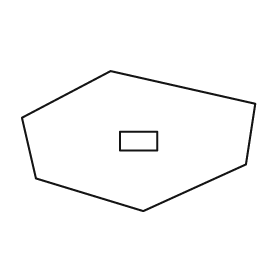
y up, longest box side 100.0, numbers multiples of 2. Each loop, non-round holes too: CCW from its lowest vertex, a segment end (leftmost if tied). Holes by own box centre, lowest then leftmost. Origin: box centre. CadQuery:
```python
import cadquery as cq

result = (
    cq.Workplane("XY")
    .moveTo(2.0, -30.0)
    .lineTo(46.0, -10.0)
    .lineTo(50.0, 16.0)
    .lineTo(-12.0, 30.0)
    .lineTo(-50.0, 10.0)
    .lineTo(-44.0, -16.0)
    .close()
    .moveTo(-8.0, -4.0)
    .lineTo(8.0, -4.0)
    .lineTo(8.0, 4.0)
    .lineTo(-8.0, 4.0)
    .close()
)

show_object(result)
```